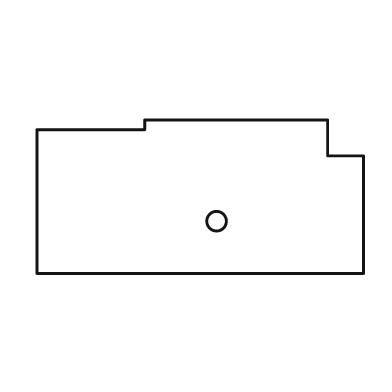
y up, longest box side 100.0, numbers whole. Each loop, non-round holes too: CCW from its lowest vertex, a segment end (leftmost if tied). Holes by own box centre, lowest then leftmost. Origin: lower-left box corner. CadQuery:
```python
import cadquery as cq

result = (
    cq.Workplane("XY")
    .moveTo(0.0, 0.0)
    .lineTo(100.0, 0.0)
    .lineTo(100.0, 36.0)
    .lineTo(89.0, 36.0)
    .lineTo(89.0, 47.0)
    .lineTo(33.0, 47.0)
    .lineTo(33.0, 44.0)
    .lineTo(0.0, 44.0)
    .close()
    .moveTo(55.0, 16.0)
    .circle(3.0)
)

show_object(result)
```